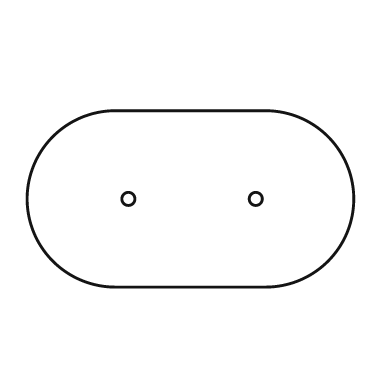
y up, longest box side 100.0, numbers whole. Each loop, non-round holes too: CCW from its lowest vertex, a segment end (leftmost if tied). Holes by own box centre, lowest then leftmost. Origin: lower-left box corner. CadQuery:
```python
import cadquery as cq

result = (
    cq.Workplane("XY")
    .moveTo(27.0, 0.0)
    .lineTo(73.0, 0.0)
    .threePointArc((100.0, 27.0), (73.0, 54.0))
    .lineTo(27.0, 54.0)
    .threePointArc((0.0, 27.0), (27.0, 0.0))
    .close()
    .moveTo(31.0, 27.0)
    .circle(2.0)
    .moveTo(70.0, 27.0)
    .circle(2.0)
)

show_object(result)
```